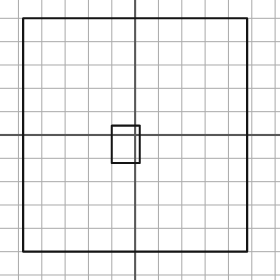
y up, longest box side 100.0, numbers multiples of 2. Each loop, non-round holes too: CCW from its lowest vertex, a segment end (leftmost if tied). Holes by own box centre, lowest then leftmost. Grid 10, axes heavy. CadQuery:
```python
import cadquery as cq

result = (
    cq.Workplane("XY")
    .moveTo(-48.0, -50.0)
    .lineTo(48.0, -50.0)
    .lineTo(48.0, 50.0)
    .lineTo(-48.0, 50.0)
    .close()
    .moveTo(-10.0, -12.0)
    .lineTo(2.0, -12.0)
    .lineTo(2.0, 4.0)
    .lineTo(-10.0, 4.0)
    .close()
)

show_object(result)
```